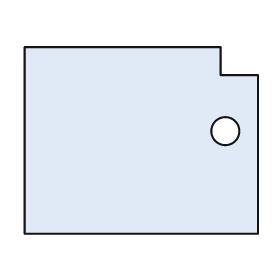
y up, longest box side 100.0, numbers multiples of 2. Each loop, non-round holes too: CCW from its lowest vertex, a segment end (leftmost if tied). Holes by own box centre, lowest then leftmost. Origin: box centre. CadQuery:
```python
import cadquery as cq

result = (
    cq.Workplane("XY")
    .moveTo(-50.0, -40.0)
    .lineTo(50.0, -40.0)
    .lineTo(50.0, 28.0)
    .lineTo(34.0, 28.0)
    .lineTo(34.0, 40.0)
    .lineTo(-50.0, 40.0)
    .close()
    .moveTo(36.0, 4.0)
    .circle(6.0)
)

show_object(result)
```